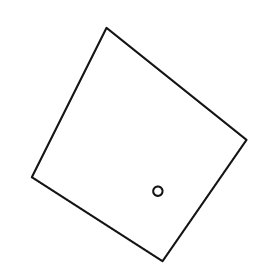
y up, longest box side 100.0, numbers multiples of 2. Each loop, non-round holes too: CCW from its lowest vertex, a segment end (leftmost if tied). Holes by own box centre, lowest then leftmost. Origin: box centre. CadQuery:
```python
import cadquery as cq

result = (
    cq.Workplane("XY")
    .moveTo(10.0, -50.0)
    .lineTo(46.0, 2.0)
    .lineTo(-14.0, 50.0)
    .lineTo(-46.0, -14.0)
    .close()
    .moveTo(8.0, -20.0)
    .circle(2.0)
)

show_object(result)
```